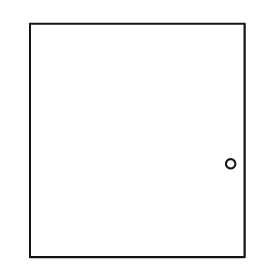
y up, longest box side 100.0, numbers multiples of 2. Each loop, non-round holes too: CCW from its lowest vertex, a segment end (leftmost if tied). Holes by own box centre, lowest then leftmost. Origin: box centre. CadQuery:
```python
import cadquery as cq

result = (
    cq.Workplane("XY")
    .moveTo(-46.0, -50.0)
    .lineTo(46.0, -50.0)
    .lineTo(46.0, 50.0)
    .lineTo(-46.0, 50.0)
    .close()
    .moveTo(40.0, -10.0)
    .circle(2.0)
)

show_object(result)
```